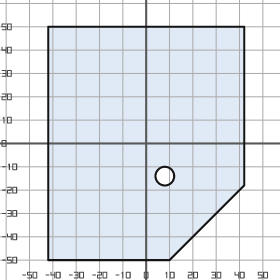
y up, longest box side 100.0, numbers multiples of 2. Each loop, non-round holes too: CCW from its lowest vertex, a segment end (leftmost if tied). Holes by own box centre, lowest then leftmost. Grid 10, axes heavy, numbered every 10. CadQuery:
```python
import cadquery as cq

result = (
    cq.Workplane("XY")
    .moveTo(-42.0, -50.0)
    .lineTo(10.0, -50.0)
    .lineTo(42.0, -18.0)
    .lineTo(42.0, 50.0)
    .lineTo(-42.0, 50.0)
    .close()
    .moveTo(8.0, -14.0)
    .circle(4.0)
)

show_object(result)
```